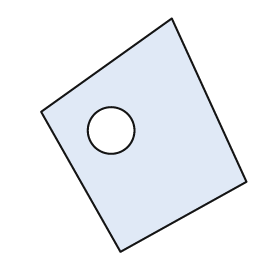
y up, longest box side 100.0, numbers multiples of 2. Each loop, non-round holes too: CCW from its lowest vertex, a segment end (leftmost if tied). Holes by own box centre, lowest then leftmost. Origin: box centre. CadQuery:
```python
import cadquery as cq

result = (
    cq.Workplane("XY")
    .moveTo(-10.0, -50.0)
    .lineTo(44.0, -20.0)
    .lineTo(12.0, 50.0)
    .lineTo(-44.0, 10.0)
    .close()
    .moveTo(-14.0, 2.0)
    .circle(10.0)
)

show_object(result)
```